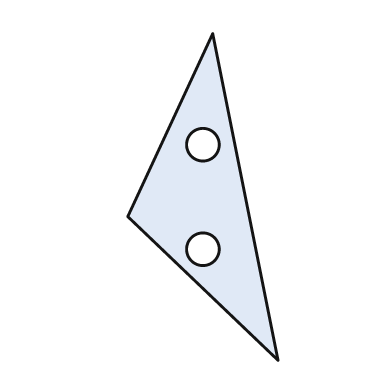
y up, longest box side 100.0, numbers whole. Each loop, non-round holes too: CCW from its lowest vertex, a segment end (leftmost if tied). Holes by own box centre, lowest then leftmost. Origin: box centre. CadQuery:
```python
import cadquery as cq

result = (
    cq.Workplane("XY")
    .moveTo(23.0, -50.0)
    .lineTo(3.0, 50.0)
    .lineTo(-23.0, -6.0)
    .close()
    .moveTo(0.0, -16.0)
    .circle(5.0)
    .moveTo(0.0, 16.0)
    .circle(5.0)
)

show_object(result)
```